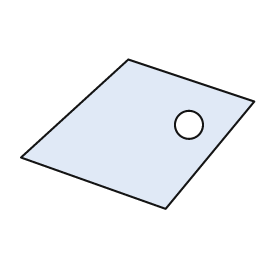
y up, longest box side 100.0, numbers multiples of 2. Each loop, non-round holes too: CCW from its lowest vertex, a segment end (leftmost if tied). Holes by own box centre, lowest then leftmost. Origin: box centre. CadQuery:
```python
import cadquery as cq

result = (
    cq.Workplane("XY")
    .moveTo(12.0, -32.0)
    .lineTo(50.0, 14.0)
    .lineTo(-4.0, 32.0)
    .lineTo(-50.0, -10.0)
    .close()
    .moveTo(22.0, 4.0)
    .circle(6.0)
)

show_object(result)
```